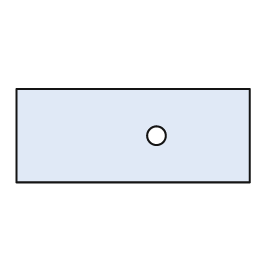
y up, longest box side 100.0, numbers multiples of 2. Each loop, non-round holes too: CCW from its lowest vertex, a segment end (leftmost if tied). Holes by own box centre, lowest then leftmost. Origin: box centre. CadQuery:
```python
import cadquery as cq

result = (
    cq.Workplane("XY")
    .moveTo(-50.0, -20.0)
    .lineTo(50.0, -20.0)
    .lineTo(50.0, 20.0)
    .lineTo(-50.0, 20.0)
    .close()
    .moveTo(10.0, 0.0)
    .circle(4.0)
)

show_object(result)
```